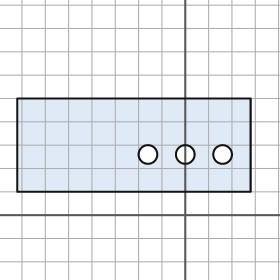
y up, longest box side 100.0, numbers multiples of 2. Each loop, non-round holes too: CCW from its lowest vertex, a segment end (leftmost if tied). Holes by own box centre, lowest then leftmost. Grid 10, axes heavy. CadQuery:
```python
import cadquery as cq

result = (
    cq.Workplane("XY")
    .moveTo(-72.0, 10.0)
    .lineTo(28.0, 10.0)
    .lineTo(28.0, 50.0)
    .lineTo(-72.0, 50.0)
    .close()
    .moveTo(-16.0, 26.0)
    .circle(4.0)
    .moveTo(0.0, 26.0)
    .circle(4.0)
    .moveTo(16.0, 26.0)
    .circle(4.0)
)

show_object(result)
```